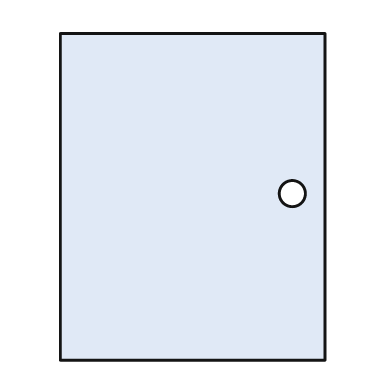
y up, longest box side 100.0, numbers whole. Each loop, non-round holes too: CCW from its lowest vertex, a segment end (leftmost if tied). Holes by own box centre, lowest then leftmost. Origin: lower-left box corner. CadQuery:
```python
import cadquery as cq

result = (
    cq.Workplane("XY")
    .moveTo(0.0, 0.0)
    .lineTo(81.0, 0.0)
    .lineTo(81.0, 100.0)
    .lineTo(0.0, 100.0)
    .close()
    .moveTo(71.0, 51.0)
    .circle(4.0)
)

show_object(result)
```